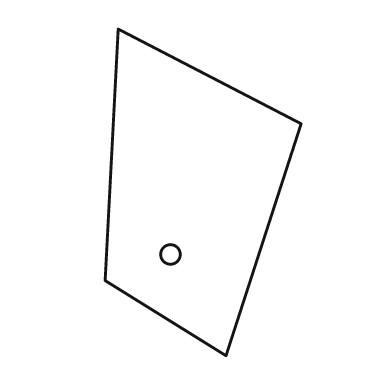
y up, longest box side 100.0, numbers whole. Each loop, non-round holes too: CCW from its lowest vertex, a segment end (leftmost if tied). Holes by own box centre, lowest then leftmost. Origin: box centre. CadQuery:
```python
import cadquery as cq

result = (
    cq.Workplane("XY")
    .moveTo(7.0, -50.0)
    .lineTo(30.0, 21.0)
    .lineTo(-26.0, 50.0)
    .lineTo(-30.0, -27.0)
    .close()
    .moveTo(-10.0, -19.0)
    .circle(3.0)
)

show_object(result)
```